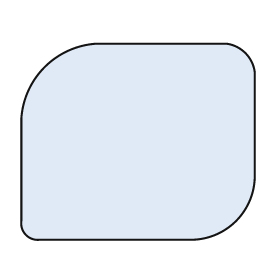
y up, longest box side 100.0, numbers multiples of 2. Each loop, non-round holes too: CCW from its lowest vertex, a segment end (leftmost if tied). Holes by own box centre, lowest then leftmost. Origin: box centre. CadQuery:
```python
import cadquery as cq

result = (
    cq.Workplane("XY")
    .moveTo(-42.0, -42.0)
    .lineTo(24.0, -42.0)
    .threePointArc((42.0, -34.0), (50.0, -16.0))
    .lineTo(50.0, 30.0)
    .threePointArc((46.0, 38.0), (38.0, 42.0))
    .lineTo(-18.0, 42.0)
    .threePointArc((-40.0, 32.0), (-50.0, 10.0))
    .lineTo(-50.0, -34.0)
    .threePointArc((-48.0, -40.0), (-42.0, -42.0))
    .close()
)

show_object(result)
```